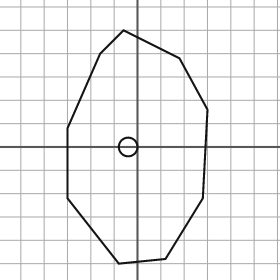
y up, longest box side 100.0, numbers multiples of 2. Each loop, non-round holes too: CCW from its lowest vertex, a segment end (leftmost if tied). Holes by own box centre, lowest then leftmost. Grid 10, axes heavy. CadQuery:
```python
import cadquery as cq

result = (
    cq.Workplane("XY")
    .moveTo(-8.0, -50.0)
    .lineTo(12.0, -48.0)
    .lineTo(28.0, -22.0)
    .lineTo(30.0, 16.0)
    .lineTo(18.0, 38.0)
    .lineTo(-6.0, 50.0)
    .lineTo(-16.0, 40.0)
    .lineTo(-30.0, 8.0)
    .lineTo(-30.0, -22.0)
    .close()
    .moveTo(-4.0, 0.0)
    .circle(4.0)
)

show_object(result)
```